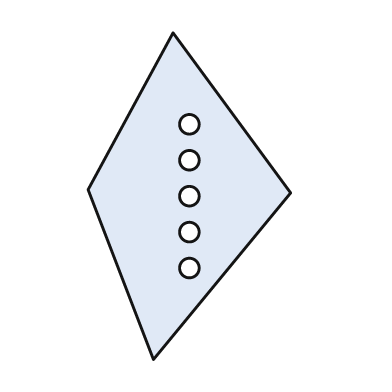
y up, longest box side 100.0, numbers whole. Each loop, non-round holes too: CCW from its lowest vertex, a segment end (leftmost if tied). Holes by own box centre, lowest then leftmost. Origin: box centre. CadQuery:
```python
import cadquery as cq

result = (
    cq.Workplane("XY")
    .moveTo(-11.0, -50.0)
    .lineTo(31.0, 1.0)
    .lineTo(-5.0, 50.0)
    .lineTo(-31.0, 2.0)
    .close()
    .moveTo(0.0, -22.0)
    .circle(3.0)
    .moveTo(0.0, -11.0)
    .circle(3.0)
    .moveTo(0.0, 0.0)
    .circle(3.0)
    .moveTo(0.0, 11.0)
    .circle(3.0)
    .moveTo(0.0, 22.0)
    .circle(3.0)
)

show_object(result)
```